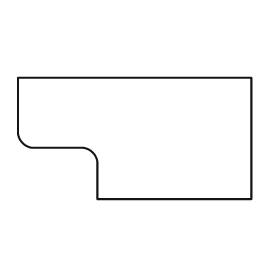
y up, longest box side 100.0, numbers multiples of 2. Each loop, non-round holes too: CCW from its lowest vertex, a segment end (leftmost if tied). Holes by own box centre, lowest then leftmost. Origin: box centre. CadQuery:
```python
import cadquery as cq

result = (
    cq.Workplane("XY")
    .moveTo(-16.0, -26.0)
    .lineTo(50.0, -26.0)
    .lineTo(50.0, 26.0)
    .lineTo(-50.0, 26.0)
    .lineTo(-50.0, 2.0)
    .threePointArc((-48.0, -2.0), (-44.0, -4.0))
    .lineTo(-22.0, -4.0)
    .threePointArc((-18.0, -6.0), (-16.0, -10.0))
    .close()
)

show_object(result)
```